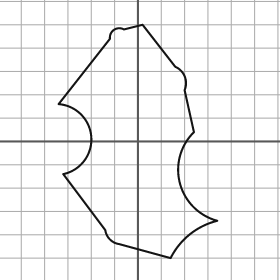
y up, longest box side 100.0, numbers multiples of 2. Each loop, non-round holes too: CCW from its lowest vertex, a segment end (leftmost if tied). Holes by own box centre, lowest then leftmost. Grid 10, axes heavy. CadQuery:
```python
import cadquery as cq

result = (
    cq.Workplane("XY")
    .moveTo(14.0, -50.0)
    .threePointArc((22.0, -40.0), (34.0, -34.0))
    .threePointArc((18.0, -18.0), (24.0, 4.0))
    .lineTo(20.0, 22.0)
    .threePointArc((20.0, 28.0), (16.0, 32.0))
    .lineTo(2.0, 50.0)
    .lineTo(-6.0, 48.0)
    .threePointArc((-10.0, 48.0), (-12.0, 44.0))
    .lineTo(-34.0, 16.0)
    .threePointArc((-20.0, 2.0), (-32.0, -14.0))
    .lineTo(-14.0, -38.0)
    .threePointArc((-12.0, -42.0), (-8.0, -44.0))
    .close()
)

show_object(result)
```